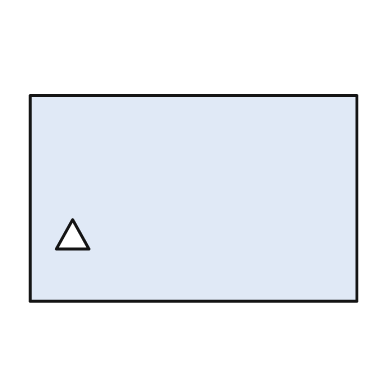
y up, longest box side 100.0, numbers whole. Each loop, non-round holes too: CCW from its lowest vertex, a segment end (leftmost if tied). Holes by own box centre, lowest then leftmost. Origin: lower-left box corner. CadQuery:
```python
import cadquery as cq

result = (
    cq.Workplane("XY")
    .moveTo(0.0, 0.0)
    .lineTo(100.0, 0.0)
    .lineTo(100.0, 63.0)
    .lineTo(0.0, 63.0)
    .close()
    .moveTo(8.0, 16.0)
    .lineTo(18.0, 16.0)
    .lineTo(13.0, 25.0)
    .close()
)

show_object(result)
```